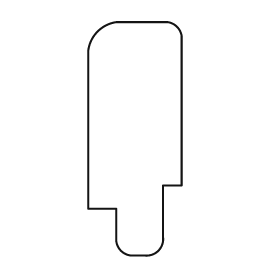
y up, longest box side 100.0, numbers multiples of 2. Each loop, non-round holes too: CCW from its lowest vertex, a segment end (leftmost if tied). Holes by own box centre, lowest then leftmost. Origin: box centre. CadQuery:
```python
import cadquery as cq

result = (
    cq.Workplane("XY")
    .moveTo(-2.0, -50.0)
    .lineTo(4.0, -50.0)
    .threePointArc((10.0, -48.0), (12.0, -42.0))
    .lineTo(12.0, -20.0)
    .lineTo(20.0, -20.0)
    .lineTo(20.0, 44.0)
    .threePointArc((18.0, 48.0), (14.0, 50.0))
    .lineTo(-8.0, 50.0)
    .threePointArc((-16.0, 46.0), (-20.0, 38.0))
    .lineTo(-20.0, -30.0)
    .lineTo(-8.0, -30.0)
    .lineTo(-8.0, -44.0)
    .threePointArc((-6.0, -48.0), (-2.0, -50.0))
    .close()
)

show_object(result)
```